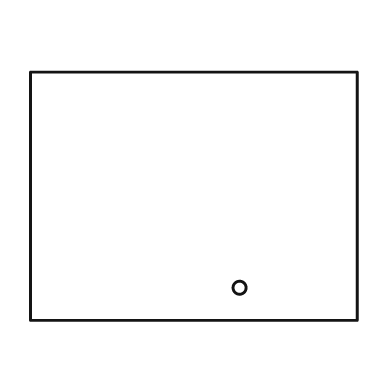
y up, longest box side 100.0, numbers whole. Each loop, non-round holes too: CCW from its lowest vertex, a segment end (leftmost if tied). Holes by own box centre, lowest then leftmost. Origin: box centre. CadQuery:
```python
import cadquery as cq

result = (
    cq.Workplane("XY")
    .moveTo(-50.0, -38.0)
    .lineTo(50.0, -38.0)
    .lineTo(50.0, 38.0)
    .lineTo(-50.0, 38.0)
    .close()
    .moveTo(14.0, -28.0)
    .circle(2.0)
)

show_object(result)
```